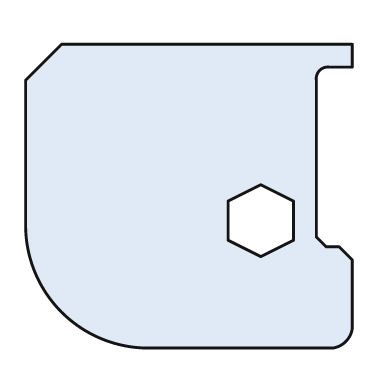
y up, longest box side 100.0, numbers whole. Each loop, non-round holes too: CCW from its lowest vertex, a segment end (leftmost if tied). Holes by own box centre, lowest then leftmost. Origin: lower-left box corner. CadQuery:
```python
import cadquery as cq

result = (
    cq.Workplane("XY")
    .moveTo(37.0, 0.0)
    .lineTo(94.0, 0.0)
    .threePointArc((98.0, 2.0), (100.0, 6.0))
    .lineTo(100.0, 27.0)
    .lineTo(96.0, 31.0)
    .lineTo(92.0, 31.0)
    .lineTo(89.0, 34.0)
    .lineTo(89.0, 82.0)
    .threePointArc((90.0, 85.0), (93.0, 86.0))
    .lineTo(100.0, 86.0)
    .lineTo(100.0, 93.0)
    .lineTo(11.0, 93.0)
    .lineTo(0.0, 82.0)
    .lineTo(0.0, 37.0)
    .threePointArc((11.0, 11.0), (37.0, 0.0))
    .close()
    .moveTo(72.0, 28.0)
    .lineTo(82.0, 33.0)
    .lineTo(82.0, 45.0)
    .lineTo(72.0, 50.0)
    .lineTo(62.0, 45.0)
    .lineTo(62.0, 33.0)
    .close()
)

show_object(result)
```